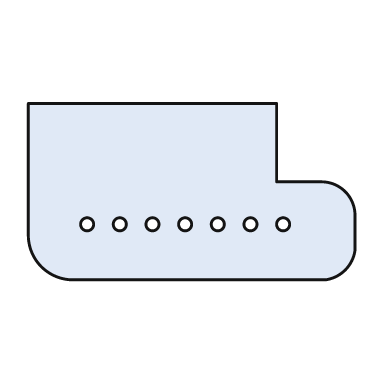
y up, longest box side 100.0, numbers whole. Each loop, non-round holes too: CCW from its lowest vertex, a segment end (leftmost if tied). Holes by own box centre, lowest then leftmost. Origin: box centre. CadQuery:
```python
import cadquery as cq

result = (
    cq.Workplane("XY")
    .moveTo(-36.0, -27.0)
    .lineTo(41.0, -27.0)
    .threePointArc((47.0, -24.0), (50.0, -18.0))
    .lineTo(50.0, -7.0)
    .threePointArc((47.0, 0.0), (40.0, 3.0))
    .lineTo(26.0, 3.0)
    .lineTo(26.0, 27.0)
    .lineTo(-50.0, 27.0)
    .lineTo(-50.0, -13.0)
    .threePointArc((-46.0, -23.0), (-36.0, -27.0))
    .close()
    .moveTo(-32.0, -10.0)
    .circle(2.0)
    .moveTo(-22.0, -10.0)
    .circle(2.0)
    .moveTo(-12.0, -10.0)
    .circle(2.0)
    .moveTo(-2.0, -10.0)
    .circle(2.0)
    .moveTo(8.0, -10.0)
    .circle(2.0)
    .moveTo(18.0, -10.0)
    .circle(2.0)
    .moveTo(28.0, -10.0)
    .circle(2.0)
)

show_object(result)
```